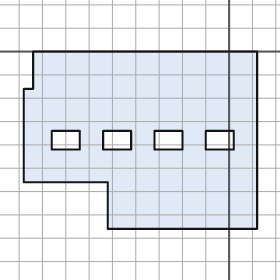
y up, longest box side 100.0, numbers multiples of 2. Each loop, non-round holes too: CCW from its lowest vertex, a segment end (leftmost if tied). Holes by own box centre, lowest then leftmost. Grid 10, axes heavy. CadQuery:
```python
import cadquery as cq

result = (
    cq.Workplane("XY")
    .moveTo(-52.0, -76.0)
    .lineTo(12.0, -76.0)
    .lineTo(12.0, 0.0)
    .lineTo(-84.0, 0.0)
    .lineTo(-84.0, -16.0)
    .lineTo(-88.0, -16.0)
    .lineTo(-88.0, -56.0)
    .lineTo(-52.0, -56.0)
    .close()
    .moveTo(-76.0, -42.0)
    .lineTo(-64.0, -42.0)
    .lineTo(-64.0, -34.0)
    .lineTo(-76.0, -34.0)
    .close()
    .moveTo(-54.0, -42.0)
    .lineTo(-42.0, -42.0)
    .lineTo(-42.0, -34.0)
    .lineTo(-54.0, -34.0)
    .close()
    .moveTo(-32.0, -42.0)
    .lineTo(-20.0, -42.0)
    .lineTo(-20.0, -34.0)
    .lineTo(-32.0, -34.0)
    .close()
    .moveTo(-10.0, -42.0)
    .lineTo(2.0, -42.0)
    .lineTo(2.0, -34.0)
    .lineTo(-10.0, -34.0)
    .close()
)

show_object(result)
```